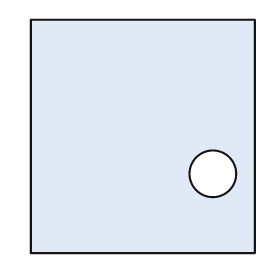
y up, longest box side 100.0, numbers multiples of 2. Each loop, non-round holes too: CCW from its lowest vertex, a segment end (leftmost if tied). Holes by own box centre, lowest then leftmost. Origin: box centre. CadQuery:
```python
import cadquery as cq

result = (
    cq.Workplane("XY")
    .moveTo(-48.0, -50.0)
    .lineTo(48.0, -50.0)
    .lineTo(48.0, 50.0)
    .lineTo(-48.0, 50.0)
    .close()
    .moveTo(30.0, -16.0)
    .circle(10.0)
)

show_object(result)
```